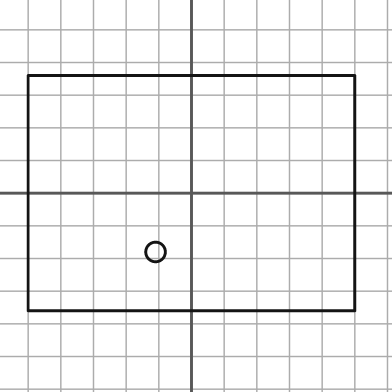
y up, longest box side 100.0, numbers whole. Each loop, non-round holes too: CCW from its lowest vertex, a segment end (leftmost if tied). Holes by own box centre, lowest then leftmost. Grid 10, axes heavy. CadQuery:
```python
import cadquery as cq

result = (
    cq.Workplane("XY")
    .moveTo(-50.0, -36.0)
    .lineTo(50.0, -36.0)
    .lineTo(50.0, 36.0)
    .lineTo(-50.0, 36.0)
    .close()
    .moveTo(-11.0, -18.0)
    .circle(3.0)
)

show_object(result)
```